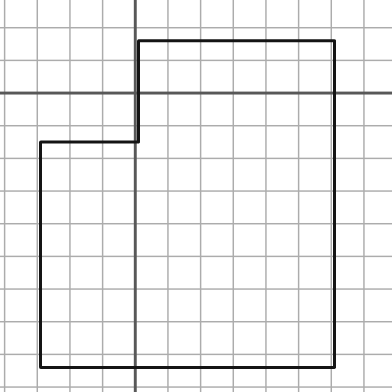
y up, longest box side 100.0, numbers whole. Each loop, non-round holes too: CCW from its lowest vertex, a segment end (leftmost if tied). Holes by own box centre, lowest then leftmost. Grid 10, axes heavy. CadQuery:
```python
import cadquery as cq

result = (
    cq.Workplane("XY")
    .moveTo(-29.0, -84.0)
    .lineTo(61.0, -84.0)
    .lineTo(61.0, 16.0)
    .lineTo(1.0, 16.0)
    .lineTo(1.0, -15.0)
    .lineTo(-29.0, -15.0)
    .close()
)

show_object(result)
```